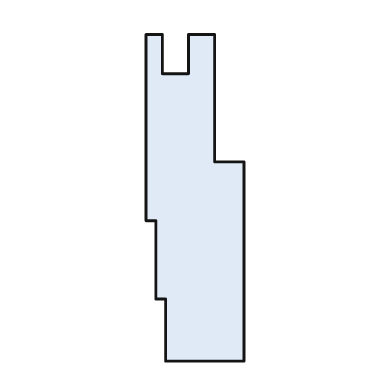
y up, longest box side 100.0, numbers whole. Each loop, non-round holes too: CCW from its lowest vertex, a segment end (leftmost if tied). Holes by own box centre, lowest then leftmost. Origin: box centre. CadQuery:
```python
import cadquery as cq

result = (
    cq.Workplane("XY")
    .moveTo(-9.0, -50.0)
    .lineTo(15.0, -50.0)
    .lineTo(15.0, 11.0)
    .lineTo(6.0, 11.0)
    .lineTo(6.0, 50.0)
    .lineTo(-2.0, 50.0)
    .lineTo(-2.0, 38.0)
    .lineTo(-10.0, 38.0)
    .lineTo(-10.0, 50.0)
    .lineTo(-15.0, 50.0)
    .lineTo(-15.0, -7.0)
    .lineTo(-12.0, -7.0)
    .lineTo(-12.0, -31.0)
    .lineTo(-9.0, -31.0)
    .close()
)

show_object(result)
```